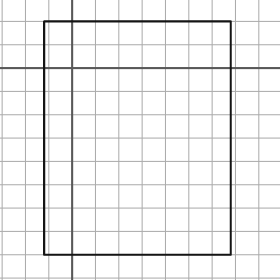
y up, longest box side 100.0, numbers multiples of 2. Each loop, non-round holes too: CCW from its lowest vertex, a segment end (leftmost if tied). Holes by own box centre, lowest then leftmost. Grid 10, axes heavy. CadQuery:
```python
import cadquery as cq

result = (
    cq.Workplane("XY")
    .moveTo(-12.0, -80.0)
    .lineTo(68.0, -80.0)
    .lineTo(68.0, 20.0)
    .lineTo(-12.0, 20.0)
    .close()
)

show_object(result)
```